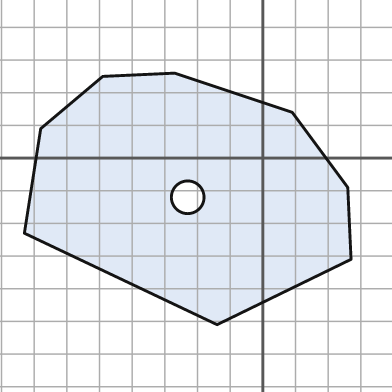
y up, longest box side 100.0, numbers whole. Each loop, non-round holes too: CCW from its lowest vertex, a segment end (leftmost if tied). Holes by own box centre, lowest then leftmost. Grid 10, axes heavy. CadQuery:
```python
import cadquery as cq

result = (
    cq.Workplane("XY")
    .moveTo(-14.0, -51.0)
    .lineTo(27.0, -31.0)
    .lineTo(26.0, -9.0)
    .lineTo(9.0, 14.0)
    .lineTo(-27.0, 26.0)
    .lineTo(-49.0, 25.0)
    .lineTo(-68.0, 9.0)
    .lineTo(-73.0, -23.0)
    .close()
    .moveTo(-23.0, -12.0)
    .circle(5.0)
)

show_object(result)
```